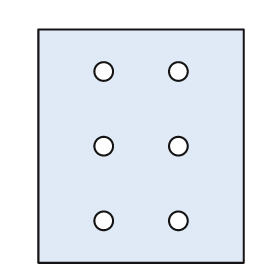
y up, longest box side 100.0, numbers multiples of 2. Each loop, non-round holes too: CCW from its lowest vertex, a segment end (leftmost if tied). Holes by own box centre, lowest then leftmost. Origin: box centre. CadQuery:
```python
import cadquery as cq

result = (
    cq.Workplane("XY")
    .moveTo(-44.0, -50.0)
    .lineTo(44.0, -50.0)
    .lineTo(44.0, 50.0)
    .lineTo(-44.0, 50.0)
    .close()
    .moveTo(-16.0, -32.0)
    .circle(4.0)
    .moveTo(16.0, -32.0)
    .circle(4.0)
    .moveTo(-16.0, 0.0)
    .circle(4.0)
    .moveTo(16.0, 0.0)
    .circle(4.0)
    .moveTo(-16.0, 32.0)
    .circle(4.0)
    .moveTo(16.0, 32.0)
    .circle(4.0)
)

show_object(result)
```